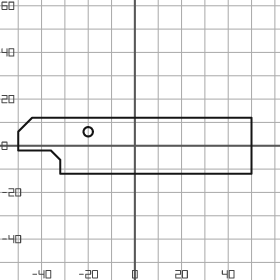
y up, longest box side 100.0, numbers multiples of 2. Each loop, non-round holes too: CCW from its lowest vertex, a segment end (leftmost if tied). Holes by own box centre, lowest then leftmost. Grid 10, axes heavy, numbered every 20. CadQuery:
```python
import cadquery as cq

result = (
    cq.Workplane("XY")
    .moveTo(-32.0, -12.0)
    .lineTo(50.0, -12.0)
    .lineTo(50.0, 12.0)
    .lineTo(-44.0, 12.0)
    .lineTo(-50.0, 6.0)
    .lineTo(-50.0, -2.0)
    .lineTo(-36.0, -2.0)
    .lineTo(-32.0, -6.0)
    .close()
    .moveTo(-20.0, 6.0)
    .circle(2.0)
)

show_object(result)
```